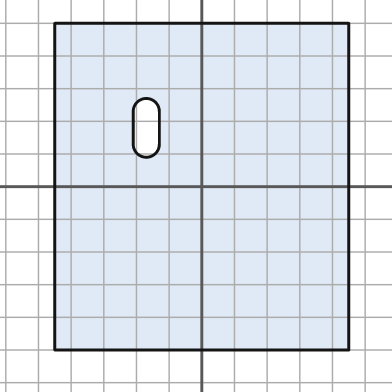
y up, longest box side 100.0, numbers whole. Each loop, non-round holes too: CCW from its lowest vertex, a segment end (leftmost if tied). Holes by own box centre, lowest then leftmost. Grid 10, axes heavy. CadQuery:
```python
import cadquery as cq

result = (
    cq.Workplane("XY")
    .moveTo(-45.0, -50.0)
    .lineTo(45.0, -50.0)
    .lineTo(45.0, 50.0)
    .lineTo(-45.0, 50.0)
    .close()
    .moveTo(-21.0, 13.0)
    .threePointArc((-17.0, 9.0), (-13.0, 13.0))
    .lineTo(-13.0, 23.0)
    .threePointArc((-17.0, 27.0), (-21.0, 23.0))
    .close()
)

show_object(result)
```